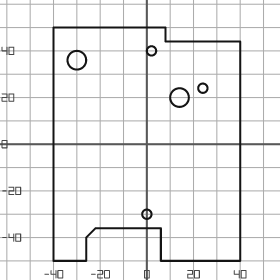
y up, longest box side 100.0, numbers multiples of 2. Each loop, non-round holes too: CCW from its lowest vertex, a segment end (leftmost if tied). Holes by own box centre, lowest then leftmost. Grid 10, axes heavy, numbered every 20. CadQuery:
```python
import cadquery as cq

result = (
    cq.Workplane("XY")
    .moveTo(-40.0, -50.0)
    .lineTo(-26.0, -50.0)
    .lineTo(-26.0, -40.0)
    .lineTo(-22.0, -36.0)
    .lineTo(6.0, -36.0)
    .lineTo(6.0, -50.0)
    .lineTo(40.0, -50.0)
    .lineTo(40.0, 44.0)
    .lineTo(8.0, 44.0)
    .lineTo(8.0, 50.0)
    .lineTo(-40.0, 50.0)
    .close()
    .moveTo(0.0, -30.0)
    .circle(2.0)
    .moveTo(14.0, 20.0)
    .circle(4.0)
    .moveTo(24.0, 24.0)
    .circle(2.0)
    .moveTo(-30.0, 36.0)
    .circle(4.0)
    .moveTo(2.0, 40.0)
    .circle(2.0)
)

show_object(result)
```